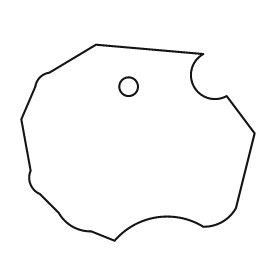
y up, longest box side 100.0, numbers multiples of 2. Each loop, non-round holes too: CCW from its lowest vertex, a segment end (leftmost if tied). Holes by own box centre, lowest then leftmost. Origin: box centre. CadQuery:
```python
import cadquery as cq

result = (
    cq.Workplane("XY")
    .moveTo(-10.0, -42.0)
    .threePointArc((8.0, -32.0), (28.0, -36.0))
    .threePointArc((36.0, -34.0), (42.0, -28.0))
    .lineTo(50.0, 4.0)
    .lineTo(38.0, 20.0)
    .threePointArc((24.0, 24.0), (28.0, 38.0))
    .lineTo(-18.0, 42.0)
    .lineTo(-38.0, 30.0)
    .threePointArc((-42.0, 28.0), (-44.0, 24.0))
    .lineTo(-50.0, 10.0)
    .lineTo(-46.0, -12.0)
    .threePointArc((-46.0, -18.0), (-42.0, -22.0))
    .lineTo(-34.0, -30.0)
    .threePointArc((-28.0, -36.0), (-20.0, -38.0))
    .close()
    .moveTo(-4.0, 24.0)
    .circle(4.0)
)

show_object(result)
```